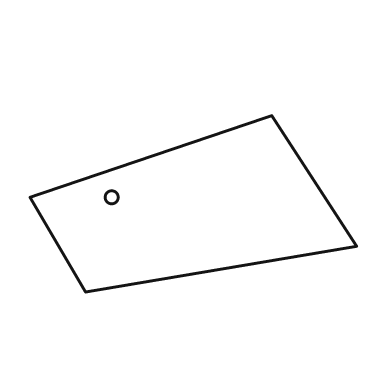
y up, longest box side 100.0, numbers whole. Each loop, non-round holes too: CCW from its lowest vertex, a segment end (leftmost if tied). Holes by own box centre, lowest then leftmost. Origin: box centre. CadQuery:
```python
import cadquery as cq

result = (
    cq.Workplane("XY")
    .moveTo(-33.0, -27.0)
    .lineTo(50.0, -13.0)
    .lineTo(24.0, 27.0)
    .lineTo(-50.0, 2.0)
    .close()
    .moveTo(-25.0, 2.0)
    .circle(2.0)
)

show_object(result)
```